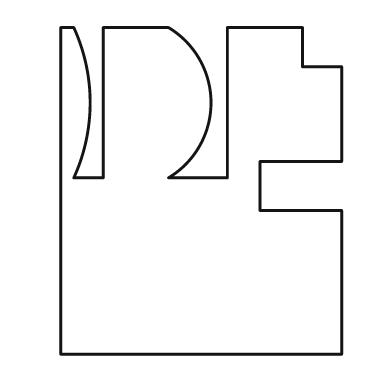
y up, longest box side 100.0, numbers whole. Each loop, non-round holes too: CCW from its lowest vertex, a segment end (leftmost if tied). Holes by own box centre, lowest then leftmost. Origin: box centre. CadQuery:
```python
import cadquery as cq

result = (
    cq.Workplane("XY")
    .moveTo(-43.0, -50.0)
    .lineTo(43.0, -50.0)
    .lineTo(43.0, -6.0)
    .lineTo(18.0, -6.0)
    .lineTo(18.0, 9.0)
    .lineTo(43.0, 9.0)
    .lineTo(43.0, 38.0)
    .lineTo(31.0, 38.0)
    .lineTo(31.0, 50.0)
    .lineTo(8.0, 50.0)
    .lineTo(8.0, 4.0)
    .lineTo(-10.0, 4.0)
    .threePointArc((3.0, 27.0), (-10.0, 50.0))
    .lineTo(-30.0, 50.0)
    .lineTo(-30.0, 4.0)
    .lineTo(-39.0, 4.0)
    .threePointArc((-34.0, 27.0), (-39.0, 50.0))
    .lineTo(-43.0, 50.0)
    .close()
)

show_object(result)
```